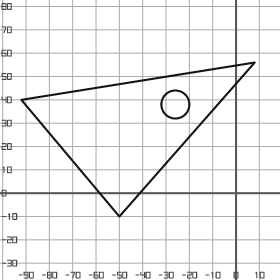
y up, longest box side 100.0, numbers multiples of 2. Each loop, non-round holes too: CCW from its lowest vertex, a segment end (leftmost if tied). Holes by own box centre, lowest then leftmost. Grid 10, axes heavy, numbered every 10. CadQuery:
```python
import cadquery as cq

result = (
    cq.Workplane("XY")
    .moveTo(-50.0, -10.0)
    .lineTo(8.0, 56.0)
    .lineTo(-92.0, 40.0)
    .close()
    .moveTo(-26.0, 38.0)
    .circle(6.0)
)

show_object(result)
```